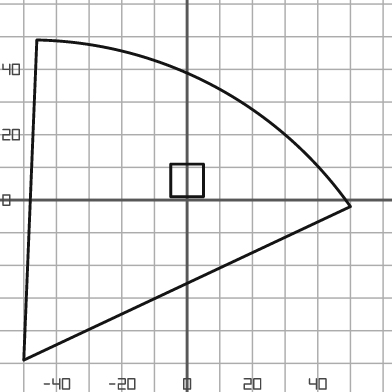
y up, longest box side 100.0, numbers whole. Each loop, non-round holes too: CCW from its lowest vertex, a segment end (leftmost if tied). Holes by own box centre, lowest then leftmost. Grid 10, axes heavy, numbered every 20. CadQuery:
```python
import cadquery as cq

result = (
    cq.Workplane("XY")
    .moveTo(-50.0, -49.0)
    .lineTo(50.0, -2.0)
    .threePointArc((8.0, 35.0), (-46.0, 49.0))
    .close()
    .moveTo(-5.0, 1.0)
    .lineTo(5.0, 1.0)
    .lineTo(5.0, 11.0)
    .lineTo(-5.0, 11.0)
    .close()
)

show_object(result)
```